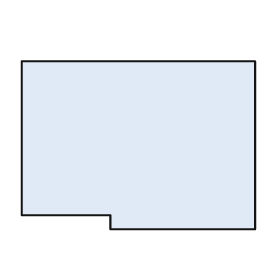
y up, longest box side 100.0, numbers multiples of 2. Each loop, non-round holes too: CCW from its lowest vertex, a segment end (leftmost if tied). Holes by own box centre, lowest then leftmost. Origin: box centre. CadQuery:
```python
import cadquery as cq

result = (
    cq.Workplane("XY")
    .moveTo(-12.0, -36.0)
    .lineTo(50.0, -36.0)
    .lineTo(50.0, 36.0)
    .lineTo(-50.0, 36.0)
    .lineTo(-50.0, -30.0)
    .lineTo(-12.0, -30.0)
    .close()
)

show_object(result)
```